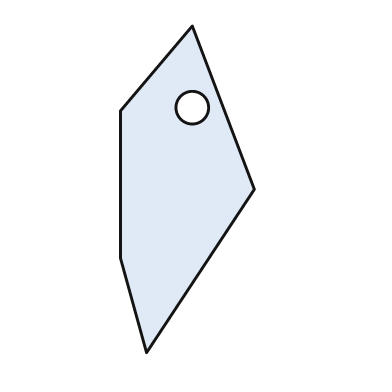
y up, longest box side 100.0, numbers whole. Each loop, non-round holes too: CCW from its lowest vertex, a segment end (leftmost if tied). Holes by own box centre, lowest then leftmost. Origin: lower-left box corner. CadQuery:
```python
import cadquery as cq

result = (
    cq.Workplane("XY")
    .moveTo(8.0, 0.0)
    .lineTo(41.0, 50.0)
    .lineTo(22.0, 100.0)
    .lineTo(0.0, 74.0)
    .lineTo(0.0, 29.0)
    .close()
    .moveTo(22.0, 75.0)
    .circle(5.0)
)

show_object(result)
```